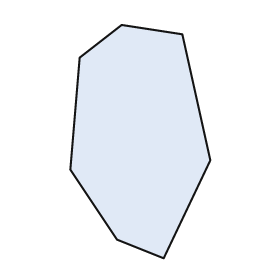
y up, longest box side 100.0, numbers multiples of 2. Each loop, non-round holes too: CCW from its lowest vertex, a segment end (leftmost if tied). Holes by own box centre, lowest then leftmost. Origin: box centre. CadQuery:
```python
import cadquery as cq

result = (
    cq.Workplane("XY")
    .moveTo(10.0, -50.0)
    .lineTo(30.0, -8.0)
    .lineTo(18.0, 46.0)
    .lineTo(-8.0, 50.0)
    .lineTo(-26.0, 36.0)
    .lineTo(-30.0, -12.0)
    .lineTo(-10.0, -42.0)
    .close()
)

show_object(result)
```